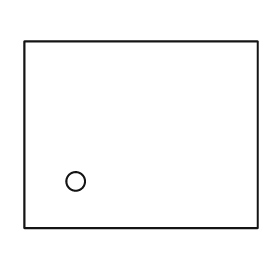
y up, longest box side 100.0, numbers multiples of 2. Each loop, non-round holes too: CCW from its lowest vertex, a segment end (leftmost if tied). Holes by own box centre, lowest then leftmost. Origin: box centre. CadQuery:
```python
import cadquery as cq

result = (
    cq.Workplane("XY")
    .moveTo(-50.0, -40.0)
    .lineTo(50.0, -40.0)
    .lineTo(50.0, 40.0)
    .lineTo(-50.0, 40.0)
    .close()
    .moveTo(-28.0, -20.0)
    .circle(4.0)
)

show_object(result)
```